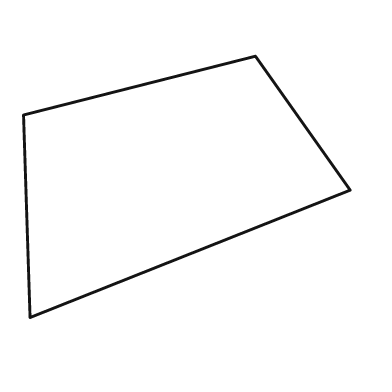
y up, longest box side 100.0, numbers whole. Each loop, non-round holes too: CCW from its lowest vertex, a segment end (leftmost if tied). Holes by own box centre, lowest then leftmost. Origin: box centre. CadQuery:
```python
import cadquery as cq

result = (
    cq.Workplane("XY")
    .moveTo(-48.0, -40.0)
    .lineTo(50.0, -1.0)
    .lineTo(21.0, 40.0)
    .lineTo(-50.0, 22.0)
    .close()
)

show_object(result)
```